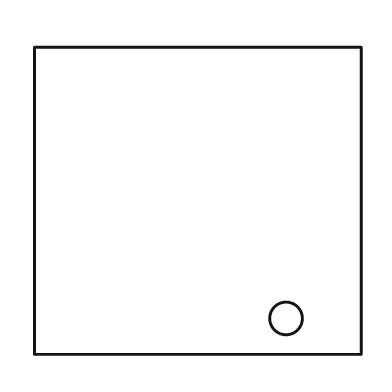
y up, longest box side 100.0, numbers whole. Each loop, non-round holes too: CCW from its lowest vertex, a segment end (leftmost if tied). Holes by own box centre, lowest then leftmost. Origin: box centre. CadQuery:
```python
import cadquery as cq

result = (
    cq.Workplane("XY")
    .moveTo(-50.0, -47.0)
    .lineTo(50.0, -47.0)
    .lineTo(50.0, 47.0)
    .lineTo(-50.0, 47.0)
    .close()
    .moveTo(27.0, -36.0)
    .circle(5.0)
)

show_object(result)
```